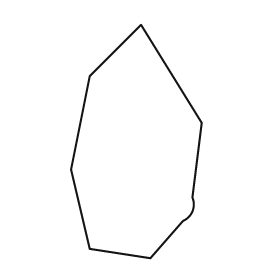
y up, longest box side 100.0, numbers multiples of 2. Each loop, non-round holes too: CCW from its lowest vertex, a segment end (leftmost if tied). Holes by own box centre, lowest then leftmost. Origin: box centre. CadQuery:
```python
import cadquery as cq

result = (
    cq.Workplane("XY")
    .moveTo(6.0, -50.0)
    .lineTo(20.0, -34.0)
    .threePointArc((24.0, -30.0), (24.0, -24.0))
    .lineTo(28.0, 8.0)
    .lineTo(2.0, 50.0)
    .lineTo(-20.0, 28.0)
    .lineTo(-28.0, -12.0)
    .lineTo(-20.0, -46.0)
    .close()
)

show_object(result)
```